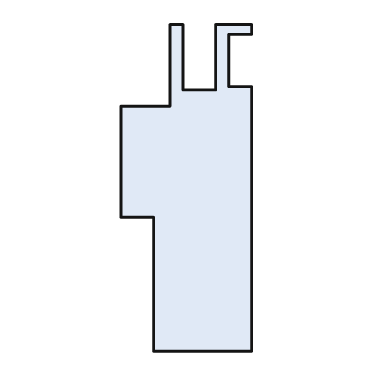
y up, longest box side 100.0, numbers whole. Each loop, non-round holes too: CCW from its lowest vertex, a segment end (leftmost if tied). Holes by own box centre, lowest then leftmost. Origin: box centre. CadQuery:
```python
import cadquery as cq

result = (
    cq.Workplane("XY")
    .moveTo(-10.0, -50.0)
    .lineTo(20.0, -50.0)
    .lineTo(20.0, 31.0)
    .lineTo(13.0, 31.0)
    .lineTo(13.0, 47.0)
    .lineTo(20.0, 47.0)
    .lineTo(20.0, 50.0)
    .lineTo(9.0, 50.0)
    .lineTo(9.0, 30.0)
    .lineTo(-1.0, 30.0)
    .lineTo(-1.0, 50.0)
    .lineTo(-5.0, 50.0)
    .lineTo(-5.0, 25.0)
    .lineTo(-20.0, 25.0)
    .lineTo(-20.0, -9.0)
    .lineTo(-10.0, -9.0)
    .close()
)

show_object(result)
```